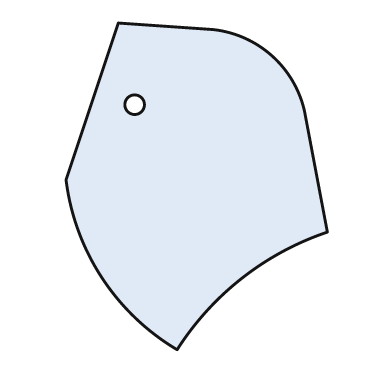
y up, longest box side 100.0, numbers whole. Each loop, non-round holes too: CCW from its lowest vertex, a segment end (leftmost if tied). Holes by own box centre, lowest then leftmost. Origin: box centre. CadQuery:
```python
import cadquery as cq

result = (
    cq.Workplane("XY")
    .moveTo(-6.0, -50.0)
    .threePointArc((14.0, -28.0), (40.0, -14.0))
    .lineTo(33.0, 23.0)
    .threePointArc((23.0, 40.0), (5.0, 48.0))
    .lineTo(-24.0, 50.0)
    .lineTo(-40.0, 2.0)
    .threePointArc((-29.0, -28.0), (-6.0, -50.0))
    .close()
    .moveTo(-19.0, 25.0)
    .circle(3.0)
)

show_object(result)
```